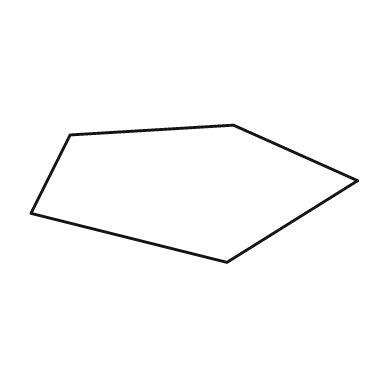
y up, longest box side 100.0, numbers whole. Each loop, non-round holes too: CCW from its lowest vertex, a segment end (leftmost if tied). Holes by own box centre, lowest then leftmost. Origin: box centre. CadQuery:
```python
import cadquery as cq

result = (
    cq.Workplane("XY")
    .moveTo(10.0, -21.0)
    .lineTo(50.0, 4.0)
    .lineTo(12.0, 21.0)
    .lineTo(-38.0, 18.0)
    .lineTo(-50.0, -6.0)
    .close()
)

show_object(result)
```